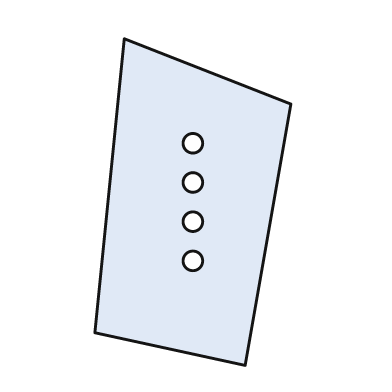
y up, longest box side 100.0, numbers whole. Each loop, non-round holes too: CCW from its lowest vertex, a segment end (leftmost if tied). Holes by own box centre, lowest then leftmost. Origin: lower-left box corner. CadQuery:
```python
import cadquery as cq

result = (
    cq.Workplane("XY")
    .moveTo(46.0, 0.0)
    .lineTo(60.0, 80.0)
    .lineTo(9.0, 100.0)
    .lineTo(0.0, 10.0)
    .close()
    .moveTo(30.0, 32.0)
    .circle(3.0)
    .moveTo(30.0, 44.0)
    .circle(3.0)
    .moveTo(30.0, 56.0)
    .circle(3.0)
    .moveTo(30.0, 68.0)
    .circle(3.0)
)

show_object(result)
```